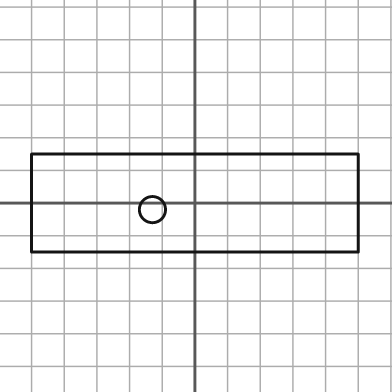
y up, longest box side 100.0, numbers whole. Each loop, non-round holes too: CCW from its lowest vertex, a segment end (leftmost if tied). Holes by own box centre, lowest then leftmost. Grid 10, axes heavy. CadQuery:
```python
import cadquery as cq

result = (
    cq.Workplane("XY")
    .moveTo(-50.0, -15.0)
    .lineTo(50.0, -15.0)
    .lineTo(50.0, 15.0)
    .lineTo(-50.0, 15.0)
    .close()
    .moveTo(-13.0, -2.0)
    .circle(4.0)
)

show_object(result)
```